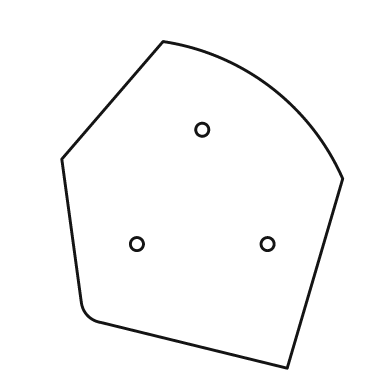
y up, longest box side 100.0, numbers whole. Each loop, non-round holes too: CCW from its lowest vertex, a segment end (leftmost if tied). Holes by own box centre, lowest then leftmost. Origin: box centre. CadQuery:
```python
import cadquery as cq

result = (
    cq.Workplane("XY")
    .moveTo(26.0, -50.0)
    .lineTo(43.0, 8.0)
    .threePointArc((21.0, 36.0), (-12.0, 50.0))
    .lineTo(-43.0, 14.0)
    .lineTo(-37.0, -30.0)
    .threePointArc((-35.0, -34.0), (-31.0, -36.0))
    .close()
    .moveTo(-20.0, -12.0)
    .circle(2.0)
    .moveTo(20.0, -12.0)
    .circle(2.0)
    .moveTo(0.0, 23.0)
    .circle(2.0)
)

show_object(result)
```